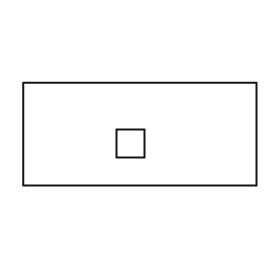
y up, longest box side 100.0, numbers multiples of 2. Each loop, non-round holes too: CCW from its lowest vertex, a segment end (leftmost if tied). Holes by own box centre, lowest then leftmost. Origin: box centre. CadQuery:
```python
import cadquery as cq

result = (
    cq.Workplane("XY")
    .moveTo(-50.0, -22.0)
    .lineTo(50.0, -22.0)
    .lineTo(50.0, 22.0)
    .lineTo(-50.0, 22.0)
    .close()
    .moveTo(-10.0, -10.0)
    .lineTo(2.0, -10.0)
    .lineTo(2.0, 2.0)
    .lineTo(-10.0, 2.0)
    .close()
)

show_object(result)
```